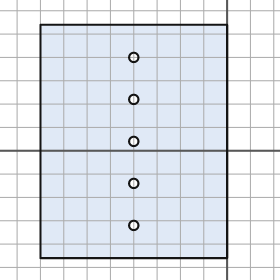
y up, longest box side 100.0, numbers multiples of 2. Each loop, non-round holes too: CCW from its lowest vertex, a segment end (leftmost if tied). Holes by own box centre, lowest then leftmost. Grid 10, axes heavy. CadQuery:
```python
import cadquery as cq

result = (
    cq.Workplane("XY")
    .moveTo(-80.0, -46.0)
    .lineTo(0.0, -46.0)
    .lineTo(0.0, 54.0)
    .lineTo(-80.0, 54.0)
    .close()
    .moveTo(-40.0, -32.0)
    .circle(2.0)
    .moveTo(-40.0, -14.0)
    .circle(2.0)
    .moveTo(-40.0, 4.0)
    .circle(2.0)
    .moveTo(-40.0, 22.0)
    .circle(2.0)
    .moveTo(-40.0, 40.0)
    .circle(2.0)
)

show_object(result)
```